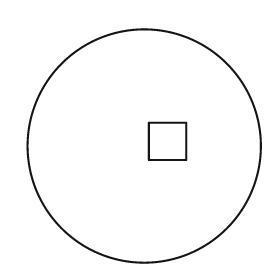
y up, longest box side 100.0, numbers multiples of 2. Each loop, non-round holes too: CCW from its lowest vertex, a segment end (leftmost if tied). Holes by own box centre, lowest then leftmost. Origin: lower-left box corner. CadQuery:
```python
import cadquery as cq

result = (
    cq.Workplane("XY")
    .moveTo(50.0, 50.0)
    .circle(50.0)
    .moveTo(52.0, 44.0)
    .lineTo(68.0, 44.0)
    .lineTo(68.0, 60.0)
    .lineTo(52.0, 60.0)
    .close()
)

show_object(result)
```